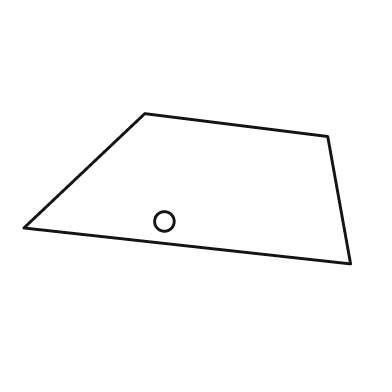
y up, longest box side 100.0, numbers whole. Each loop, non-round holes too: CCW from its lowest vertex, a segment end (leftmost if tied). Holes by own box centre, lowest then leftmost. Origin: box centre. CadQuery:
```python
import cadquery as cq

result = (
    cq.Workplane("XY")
    .moveTo(50.0, -23.0)
    .lineTo(43.0, 16.0)
    .lineTo(-13.0, 23.0)
    .lineTo(-50.0, -12.0)
    .close()
    .moveTo(-7.0, -10.0)
    .circle(3.0)
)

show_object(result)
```